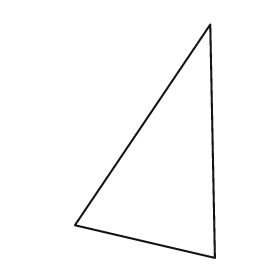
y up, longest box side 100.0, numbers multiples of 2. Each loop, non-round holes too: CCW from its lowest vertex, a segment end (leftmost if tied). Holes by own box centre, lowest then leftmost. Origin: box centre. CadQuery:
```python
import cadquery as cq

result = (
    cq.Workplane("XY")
    .moveTo(30.0, -50.0)
    .lineTo(28.0, 50.0)
    .lineTo(-30.0, -36.0)
    .close()
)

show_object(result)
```